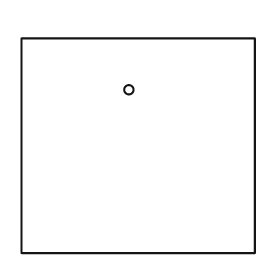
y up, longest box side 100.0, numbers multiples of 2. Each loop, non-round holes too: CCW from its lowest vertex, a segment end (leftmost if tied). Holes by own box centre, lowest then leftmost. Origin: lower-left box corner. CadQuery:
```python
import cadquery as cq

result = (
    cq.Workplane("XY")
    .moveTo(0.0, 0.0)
    .lineTo(100.0, 0.0)
    .lineTo(100.0, 92.0)
    .lineTo(0.0, 92.0)
    .close()
    .moveTo(46.0, 70.0)
    .circle(2.0)
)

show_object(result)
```